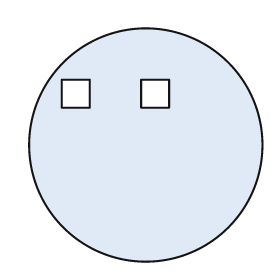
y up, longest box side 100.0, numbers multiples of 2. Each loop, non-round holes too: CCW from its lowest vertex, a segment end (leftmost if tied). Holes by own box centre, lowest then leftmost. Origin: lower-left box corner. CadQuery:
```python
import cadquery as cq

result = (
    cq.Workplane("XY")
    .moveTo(50.0, 50.0)
    .circle(50.0)
    .moveTo(14.0, 66.0)
    .lineTo(26.0, 66.0)
    .lineTo(26.0, 78.0)
    .lineTo(14.0, 78.0)
    .close()
    .moveTo(48.0, 66.0)
    .lineTo(60.0, 66.0)
    .lineTo(60.0, 78.0)
    .lineTo(48.0, 78.0)
    .close()
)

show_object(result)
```